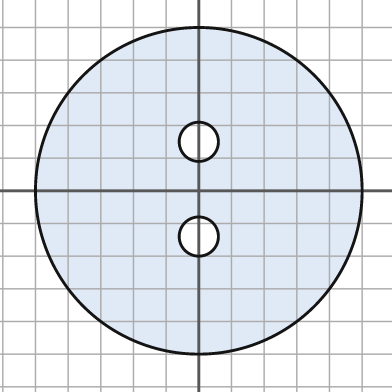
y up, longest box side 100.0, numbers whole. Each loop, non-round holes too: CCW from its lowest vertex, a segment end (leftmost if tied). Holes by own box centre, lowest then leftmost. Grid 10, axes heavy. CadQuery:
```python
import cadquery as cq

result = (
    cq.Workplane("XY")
    .moveTo(0.0, 0.0)
    .circle(50.0)
    .moveTo(0.0, -14.0)
    .circle(6.0)
    .moveTo(0.0, 15.0)
    .circle(6.0)
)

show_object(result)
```